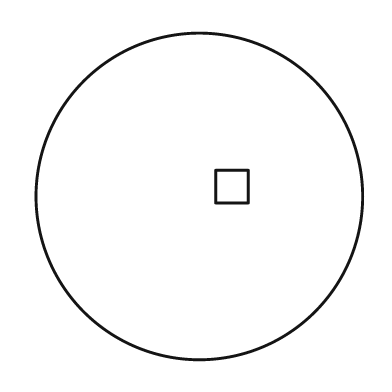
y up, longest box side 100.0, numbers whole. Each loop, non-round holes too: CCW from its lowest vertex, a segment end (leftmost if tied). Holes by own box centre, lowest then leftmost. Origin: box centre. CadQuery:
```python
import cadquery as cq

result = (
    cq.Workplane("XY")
    .moveTo(0.0, 0.0)
    .circle(50.0)
    .moveTo(5.0, -2.0)
    .lineTo(15.0, -2.0)
    .lineTo(15.0, 8.0)
    .lineTo(5.0, 8.0)
    .close()
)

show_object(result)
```